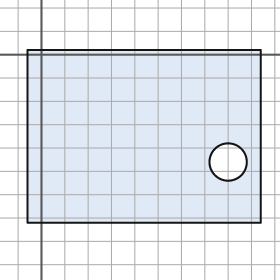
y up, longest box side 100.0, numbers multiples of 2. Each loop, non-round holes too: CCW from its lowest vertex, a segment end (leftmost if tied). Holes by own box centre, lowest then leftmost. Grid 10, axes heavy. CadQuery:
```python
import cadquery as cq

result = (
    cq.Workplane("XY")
    .moveTo(-6.0, -72.0)
    .lineTo(94.0, -72.0)
    .lineTo(94.0, 2.0)
    .lineTo(-6.0, 2.0)
    .close()
    .moveTo(80.0, -46.0)
    .circle(8.0)
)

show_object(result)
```